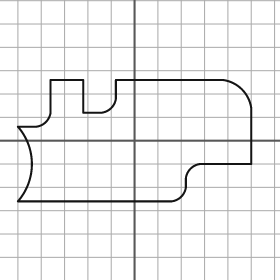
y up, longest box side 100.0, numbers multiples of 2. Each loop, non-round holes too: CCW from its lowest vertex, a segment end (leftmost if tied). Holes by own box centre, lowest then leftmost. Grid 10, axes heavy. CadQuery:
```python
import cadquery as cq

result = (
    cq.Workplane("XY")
    .moveTo(-50.0, -26.0)
    .lineTo(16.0, -26.0)
    .threePointArc((20.0, -24.0), (22.0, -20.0))
    .lineTo(22.0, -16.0)
    .threePointArc((24.0, -12.0), (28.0, -10.0))
    .lineTo(50.0, -10.0)
    .lineTo(50.0, 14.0)
    .threePointArc((46.0, 22.0), (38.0, 26.0))
    .lineTo(-8.0, 26.0)
    .lineTo(-8.0, 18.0)
    .threePointArc((-10.0, 14.0), (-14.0, 12.0))
    .lineTo(-22.0, 12.0)
    .lineTo(-22.0, 26.0)
    .lineTo(-36.0, 26.0)
    .lineTo(-36.0, 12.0)
    .threePointArc((-38.0, 8.0), (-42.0, 6.0))
    .lineTo(-50.0, 6.0)
    .threePointArc((-44.0, -10.0), (-50.0, -26.0))
    .close()
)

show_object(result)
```